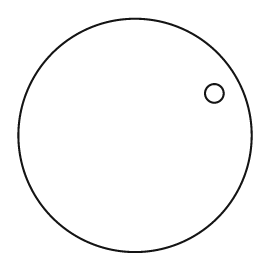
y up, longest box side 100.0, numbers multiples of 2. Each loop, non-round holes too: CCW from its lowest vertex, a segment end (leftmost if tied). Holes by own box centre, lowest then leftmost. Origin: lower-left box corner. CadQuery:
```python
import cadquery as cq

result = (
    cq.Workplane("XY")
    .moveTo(50.0, 50.0)
    .circle(50.0)
    .moveTo(84.0, 68.0)
    .circle(4.0)
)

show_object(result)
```